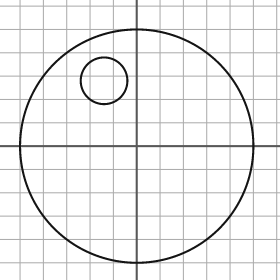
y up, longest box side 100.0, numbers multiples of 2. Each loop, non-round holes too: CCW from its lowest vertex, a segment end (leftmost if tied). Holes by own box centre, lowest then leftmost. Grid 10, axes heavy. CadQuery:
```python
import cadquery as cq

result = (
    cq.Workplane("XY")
    .moveTo(0.0, 0.0)
    .circle(50.0)
    .moveTo(-14.0, 28.0)
    .circle(10.0)
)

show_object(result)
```